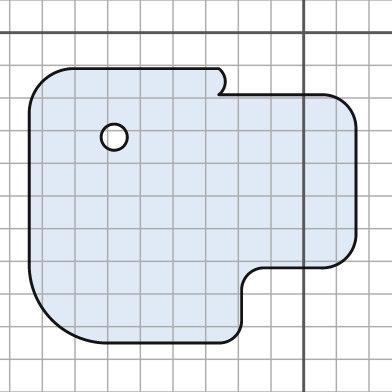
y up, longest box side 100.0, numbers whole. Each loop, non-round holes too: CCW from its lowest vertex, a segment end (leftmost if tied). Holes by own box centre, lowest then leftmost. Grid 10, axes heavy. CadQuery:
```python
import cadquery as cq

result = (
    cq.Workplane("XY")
    .moveTo(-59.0, -95.0)
    .lineTo(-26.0, -95.0)
    .threePointArc((-21.0, -93.0), (-19.0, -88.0))
    .lineTo(-19.0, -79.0)
    .threePointArc((-17.0, -74.0), (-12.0, -72.0))
    .lineTo(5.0, -72.0)
    .threePointArc((13.0, -69.0), (16.0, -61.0))
    .lineTo(16.0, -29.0)
    .threePointArc((13.0, -22.0), (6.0, -19.0))
    .lineTo(-26.0, -19.0)
    .threePointArc((-24.0, -15.0), (-26.0, -11.0))
    .lineTo(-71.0, -11.0)
    .threePointArc((-80.0, -15.0), (-84.0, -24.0))
    .lineTo(-84.0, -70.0)
    .threePointArc((-77.0, -88.0), (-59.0, -95.0))
    .close()
    .moveTo(-58.0, -32.0)
    .circle(4.0)
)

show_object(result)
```